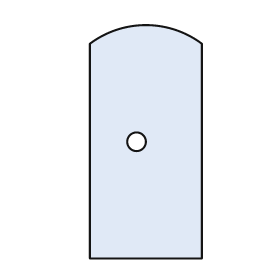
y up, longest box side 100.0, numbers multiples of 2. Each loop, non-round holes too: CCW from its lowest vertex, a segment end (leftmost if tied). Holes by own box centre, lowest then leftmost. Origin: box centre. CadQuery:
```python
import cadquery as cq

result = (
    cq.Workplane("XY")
    .moveTo(-24.0, -50.0)
    .lineTo(24.0, -50.0)
    .lineTo(24.0, 42.0)
    .threePointArc((0.0, 50.0), (-24.0, 42.0))
    .close()
    .moveTo(-4.0, 0.0)
    .circle(4.0)
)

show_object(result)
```